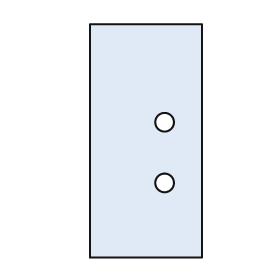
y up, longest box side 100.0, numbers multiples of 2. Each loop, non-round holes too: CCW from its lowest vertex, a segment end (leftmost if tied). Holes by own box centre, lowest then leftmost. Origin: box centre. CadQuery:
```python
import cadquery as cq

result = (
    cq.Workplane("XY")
    .moveTo(-24.0, -50.0)
    .lineTo(24.0, -50.0)
    .lineTo(24.0, 50.0)
    .lineTo(-24.0, 50.0)
    .close()
    .moveTo(8.0, -18.0)
    .circle(4.0)
    .moveTo(8.0, 8.0)
    .circle(4.0)
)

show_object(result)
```